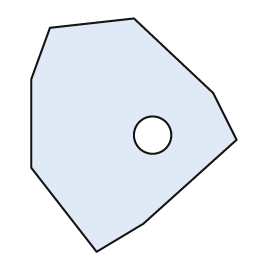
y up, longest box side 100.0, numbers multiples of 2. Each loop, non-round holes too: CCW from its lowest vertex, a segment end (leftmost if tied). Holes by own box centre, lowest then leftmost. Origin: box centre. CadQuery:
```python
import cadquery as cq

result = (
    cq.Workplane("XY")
    .moveTo(-16.0, -50.0)
    .lineTo(4.0, -38.0)
    .lineTo(44.0, -2.0)
    .lineTo(34.0, 18.0)
    .lineTo(0.0, 50.0)
    .lineTo(-36.0, 46.0)
    .lineTo(-44.0, 24.0)
    .lineTo(-44.0, -14.0)
    .close()
    .moveTo(8.0, 0.0)
    .circle(8.0)
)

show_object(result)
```